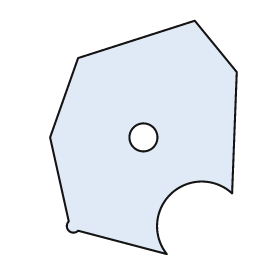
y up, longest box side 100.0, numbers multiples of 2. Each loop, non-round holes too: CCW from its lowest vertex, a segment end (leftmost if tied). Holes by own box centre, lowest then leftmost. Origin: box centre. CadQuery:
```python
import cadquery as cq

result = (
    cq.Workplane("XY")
    .moveTo(10.0, -50.0)
    .threePointArc((12.0, -24.0), (38.0, -24.0))
    .lineTo(40.0, 28.0)
    .lineTo(22.0, 50.0)
    .lineTo(-28.0, 34.0)
    .lineTo(-40.0, 0.0)
    .lineTo(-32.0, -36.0)
    .threePointArc((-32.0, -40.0), (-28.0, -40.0))
    .close()
    .moveTo(0.0, 0.0)
    .circle(6.0)
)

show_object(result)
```